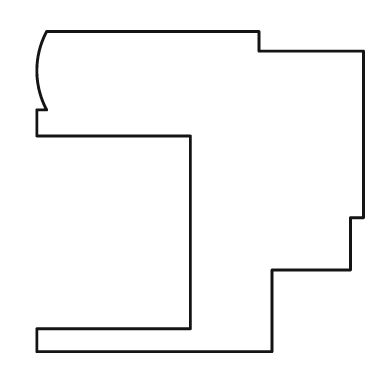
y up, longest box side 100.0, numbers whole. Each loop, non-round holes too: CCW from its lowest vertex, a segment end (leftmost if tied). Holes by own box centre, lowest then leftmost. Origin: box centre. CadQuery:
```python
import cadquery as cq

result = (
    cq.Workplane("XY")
    .moveTo(-50.0, -49.0)
    .lineTo(22.0, -49.0)
    .lineTo(22.0, -24.0)
    .lineTo(46.0, -24.0)
    .lineTo(46.0, -8.0)
    .lineTo(50.0, -8.0)
    .lineTo(50.0, 43.0)
    .lineTo(18.0, 43.0)
    .lineTo(18.0, 49.0)
    .lineTo(-47.0, 49.0)
    .threePointArc((-50.0, 37.0), (-47.0, 25.0))
    .lineTo(-50.0, 25.0)
    .lineTo(-50.0, 17.0)
    .lineTo(-3.0, 17.0)
    .lineTo(-3.0, -42.0)
    .lineTo(-50.0, -42.0)
    .close()
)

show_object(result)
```